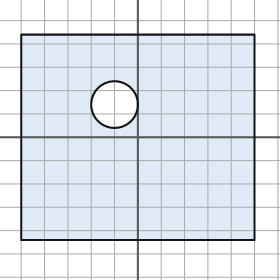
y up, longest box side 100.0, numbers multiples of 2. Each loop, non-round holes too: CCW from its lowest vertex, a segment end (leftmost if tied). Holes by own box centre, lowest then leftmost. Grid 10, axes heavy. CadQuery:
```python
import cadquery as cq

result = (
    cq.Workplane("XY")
    .moveTo(-50.0, -44.0)
    .lineTo(50.0, -44.0)
    .lineTo(50.0, 44.0)
    .lineTo(-50.0, 44.0)
    .close()
    .moveTo(-10.0, 14.0)
    .circle(10.0)
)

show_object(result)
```